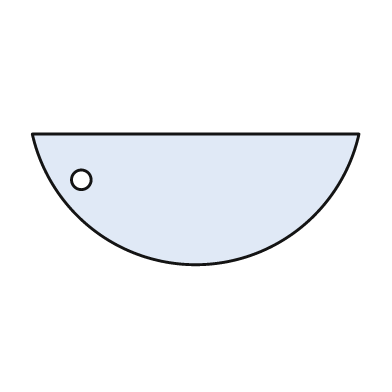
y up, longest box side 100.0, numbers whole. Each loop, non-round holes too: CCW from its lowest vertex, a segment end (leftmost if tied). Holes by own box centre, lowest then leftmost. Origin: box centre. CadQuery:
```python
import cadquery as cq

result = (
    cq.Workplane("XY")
    .moveTo(-50.0, 20.0)
    .threePointArc((0.0, -20.0), (50.0, 20.0))
    .close()
    .moveTo(-35.0, 6.0)
    .circle(3.0)
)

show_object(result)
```